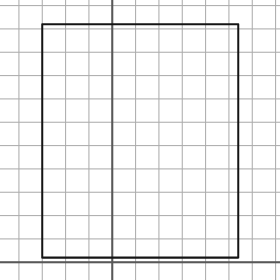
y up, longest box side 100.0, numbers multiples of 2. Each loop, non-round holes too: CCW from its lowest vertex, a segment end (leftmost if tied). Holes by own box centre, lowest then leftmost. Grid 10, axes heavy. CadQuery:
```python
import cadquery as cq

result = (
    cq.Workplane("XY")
    .moveTo(-30.0, 2.0)
    .lineTo(54.0, 2.0)
    .lineTo(54.0, 102.0)
    .lineTo(-30.0, 102.0)
    .close()
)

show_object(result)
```